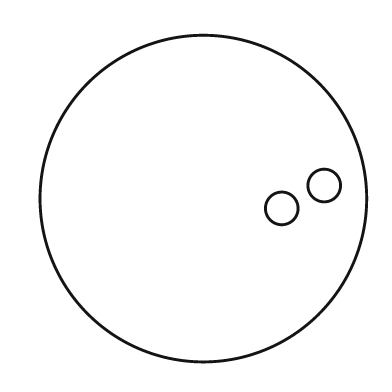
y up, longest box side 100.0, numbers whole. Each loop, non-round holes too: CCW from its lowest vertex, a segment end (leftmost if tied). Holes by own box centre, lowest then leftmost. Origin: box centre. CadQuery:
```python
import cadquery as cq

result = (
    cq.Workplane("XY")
    .moveTo(0.0, 0.0)
    .circle(50.0)
    .moveTo(24.0, -3.0)
    .circle(5.0)
    .moveTo(37.0, 4.0)
    .circle(5.0)
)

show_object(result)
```